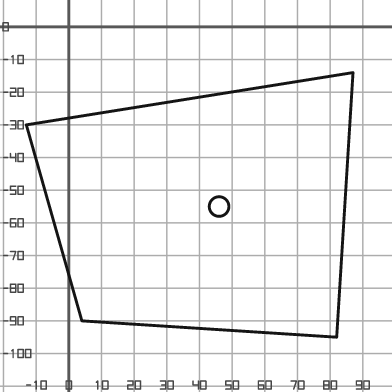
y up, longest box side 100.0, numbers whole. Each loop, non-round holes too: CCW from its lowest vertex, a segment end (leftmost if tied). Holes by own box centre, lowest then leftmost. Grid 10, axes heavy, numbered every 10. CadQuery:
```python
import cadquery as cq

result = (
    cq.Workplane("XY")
    .moveTo(82.0, -95.0)
    .lineTo(87.0, -14.0)
    .lineTo(-13.0, -30.0)
    .lineTo(4.0, -90.0)
    .close()
    .moveTo(46.0, -55.0)
    .circle(3.0)
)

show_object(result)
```